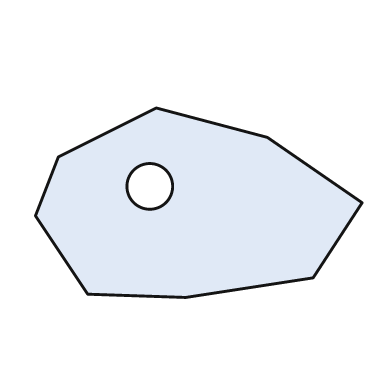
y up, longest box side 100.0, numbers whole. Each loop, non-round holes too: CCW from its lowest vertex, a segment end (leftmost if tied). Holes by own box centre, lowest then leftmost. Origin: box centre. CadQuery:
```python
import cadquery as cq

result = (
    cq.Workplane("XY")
    .moveTo(-4.0, -29.0)
    .lineTo(35.0, -23.0)
    .lineTo(50.0, 0.0)
    .lineTo(21.0, 20.0)
    .lineTo(-13.0, 29.0)
    .lineTo(-43.0, 14.0)
    .lineTo(-50.0, -4.0)
    .lineTo(-34.0, -28.0)
    .close()
    .moveTo(-15.0, 5.0)
    .circle(7.0)
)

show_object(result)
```